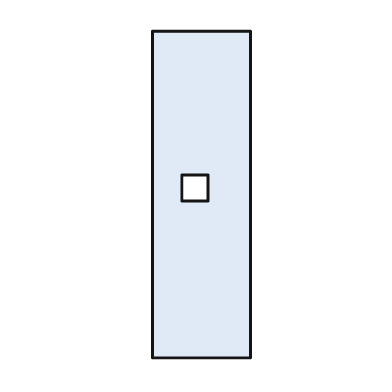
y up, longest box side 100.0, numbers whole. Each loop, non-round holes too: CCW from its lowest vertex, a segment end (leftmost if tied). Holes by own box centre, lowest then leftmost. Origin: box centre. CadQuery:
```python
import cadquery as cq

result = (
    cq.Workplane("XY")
    .moveTo(-15.0, -50.0)
    .lineTo(15.0, -50.0)
    .lineTo(15.0, 50.0)
    .lineTo(-15.0, 50.0)
    .close()
    .moveTo(-6.0, -2.0)
    .lineTo(2.0, -2.0)
    .lineTo(2.0, 6.0)
    .lineTo(-6.0, 6.0)
    .close()
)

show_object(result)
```